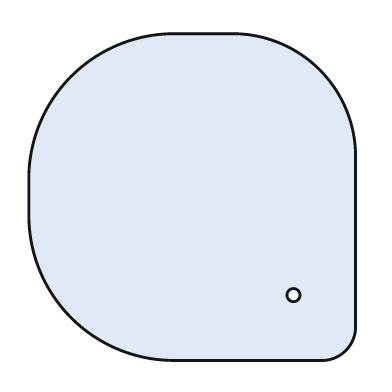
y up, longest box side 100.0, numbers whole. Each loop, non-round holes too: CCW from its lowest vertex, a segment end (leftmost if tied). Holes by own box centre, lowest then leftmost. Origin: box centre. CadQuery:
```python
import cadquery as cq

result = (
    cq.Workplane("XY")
    .moveTo(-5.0, -50.0)
    .lineTo(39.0, -50.0)
    .threePointArc((47.0, -47.0), (50.0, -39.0))
    .lineTo(50.0, 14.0)
    .threePointArc((39.0, 39.0), (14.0, 50.0))
    .lineTo(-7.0, 50.0)
    .threePointArc((-37.0, 37.0), (-50.0, 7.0))
    .lineTo(-50.0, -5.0)
    .threePointArc((-37.0, -37.0), (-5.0, -50.0))
    .close()
    .moveTo(31.0, -30.0)
    .circle(2.0)
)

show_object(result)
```